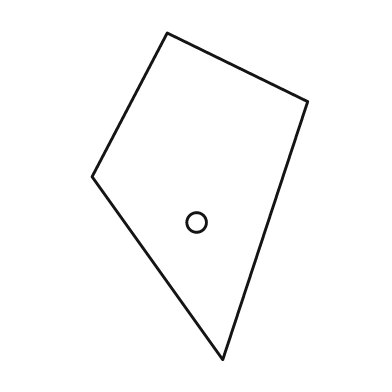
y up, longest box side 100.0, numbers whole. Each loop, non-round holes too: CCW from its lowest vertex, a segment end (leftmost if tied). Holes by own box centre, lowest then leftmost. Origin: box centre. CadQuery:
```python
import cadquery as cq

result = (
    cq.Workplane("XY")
    .moveTo(7.0, -50.0)
    .lineTo(33.0, 29.0)
    .lineTo(-10.0, 50.0)
    .lineTo(-33.0, 6.0)
    .close()
    .moveTo(-1.0, -8.0)
    .circle(3.0)
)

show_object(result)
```